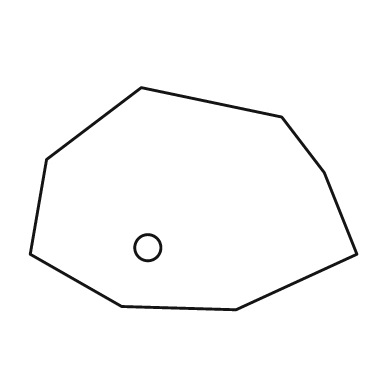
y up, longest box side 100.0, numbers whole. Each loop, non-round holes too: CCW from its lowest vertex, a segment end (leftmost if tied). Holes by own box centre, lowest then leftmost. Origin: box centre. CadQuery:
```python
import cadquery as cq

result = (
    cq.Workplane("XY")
    .moveTo(13.0, -34.0)
    .lineTo(50.0, -17.0)
    .lineTo(40.0, 8.0)
    .lineTo(27.0, 25.0)
    .lineTo(-16.0, 34.0)
    .lineTo(-45.0, 12.0)
    .lineTo(-50.0, -17.0)
    .lineTo(-22.0, -33.0)
    .close()
    .moveTo(-14.0, -15.0)
    .circle(4.0)
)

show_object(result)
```